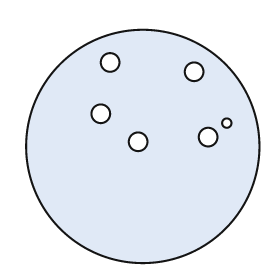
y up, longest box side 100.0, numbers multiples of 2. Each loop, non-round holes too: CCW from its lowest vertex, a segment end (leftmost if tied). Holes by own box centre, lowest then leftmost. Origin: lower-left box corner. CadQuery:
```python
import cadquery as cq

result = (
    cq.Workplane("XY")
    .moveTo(50.0, 50.0)
    .circle(50.0)
    .moveTo(48.0, 52.0)
    .circle(4.0)
    .moveTo(78.0, 54.0)
    .circle(4.0)
    .moveTo(86.0, 60.0)
    .circle(2.0)
    .moveTo(32.0, 64.0)
    .circle(4.0)
    .moveTo(72.0, 82.0)
    .circle(4.0)
    .moveTo(36.0, 86.0)
    .circle(4.0)
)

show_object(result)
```